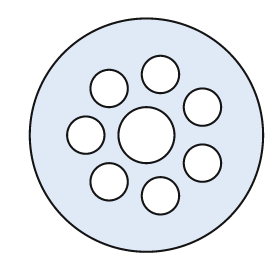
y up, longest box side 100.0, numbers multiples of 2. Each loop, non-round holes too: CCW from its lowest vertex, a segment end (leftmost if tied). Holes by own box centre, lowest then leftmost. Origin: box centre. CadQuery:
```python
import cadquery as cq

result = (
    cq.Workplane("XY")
    .moveTo(0.0, 0.0)
    .circle(50.0)
    .moveTo(6.0, -26.0)
    .circle(8.0)
    .moveTo(-16.0, -20.0)
    .circle(8.0)
    .moveTo(24.0, -12.0)
    .circle(8.0)
    .moveTo(-26.0, 0.0)
    .circle(8.0)
    .moveTo(0.0, 0.0)
    .circle(12.0)
    .moveTo(24.0, 12.0)
    .circle(8.0)
    .moveTo(-16.0, 20.0)
    .circle(8.0)
    .moveTo(6.0, 26.0)
    .circle(8.0)
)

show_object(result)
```